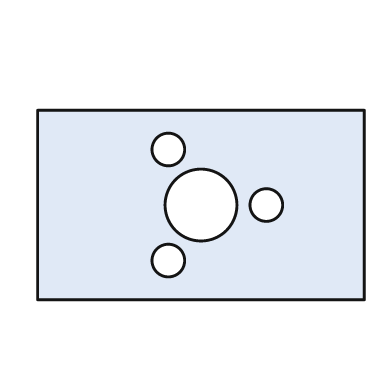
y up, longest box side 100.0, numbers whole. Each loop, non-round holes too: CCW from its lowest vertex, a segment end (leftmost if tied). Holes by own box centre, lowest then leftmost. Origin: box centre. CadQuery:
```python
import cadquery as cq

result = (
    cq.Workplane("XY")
    .moveTo(-50.0, -29.0)
    .lineTo(50.0, -29.0)
    .lineTo(50.0, 29.0)
    .lineTo(-50.0, 29.0)
    .close()
    .moveTo(-10.0, -17.0)
    .circle(5.0)
    .moveTo(0.0, 0.0)
    .circle(11.0)
    .moveTo(20.0, 0.0)
    .circle(5.0)
    .moveTo(-10.0, 17.0)
    .circle(5.0)
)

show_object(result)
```